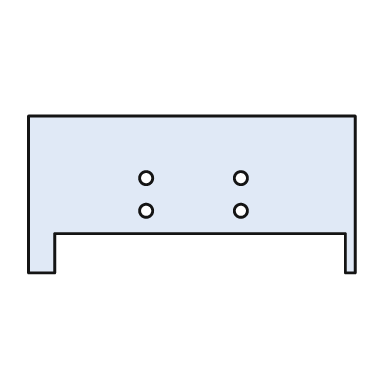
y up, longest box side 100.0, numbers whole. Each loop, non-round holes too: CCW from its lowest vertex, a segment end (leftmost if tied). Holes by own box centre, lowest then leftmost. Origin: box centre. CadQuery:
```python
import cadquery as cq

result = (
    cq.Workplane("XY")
    .moveTo(-50.0, -24.0)
    .lineTo(-42.0, -24.0)
    .lineTo(-42.0, -12.0)
    .lineTo(47.0, -12.0)
    .lineTo(47.0, -24.0)
    .lineTo(50.0, -24.0)
    .lineTo(50.0, 24.0)
    .lineTo(-50.0, 24.0)
    .close()
    .moveTo(-14.0, -5.0)
    .circle(2.0)
    .moveTo(15.0, -5.0)
    .circle(2.0)
    .moveTo(-14.0, 5.0)
    .circle(2.0)
    .moveTo(15.0, 5.0)
    .circle(2.0)
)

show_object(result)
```